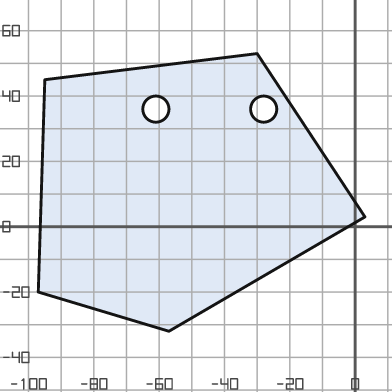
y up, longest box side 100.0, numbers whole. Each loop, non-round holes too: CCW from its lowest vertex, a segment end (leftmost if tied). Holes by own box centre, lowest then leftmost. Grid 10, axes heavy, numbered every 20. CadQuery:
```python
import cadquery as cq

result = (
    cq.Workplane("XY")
    .moveTo(-57.0, -32.0)
    .lineTo(3.0, 3.0)
    .lineTo(-30.0, 53.0)
    .lineTo(-95.0, 45.0)
    .lineTo(-97.0, -20.0)
    .close()
    .moveTo(-61.0, 36.0)
    .circle(4.0)
    .moveTo(-28.0, 36.0)
    .circle(4.0)
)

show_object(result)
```